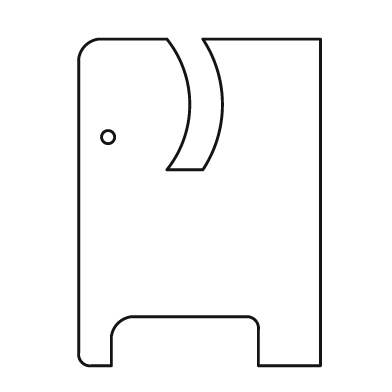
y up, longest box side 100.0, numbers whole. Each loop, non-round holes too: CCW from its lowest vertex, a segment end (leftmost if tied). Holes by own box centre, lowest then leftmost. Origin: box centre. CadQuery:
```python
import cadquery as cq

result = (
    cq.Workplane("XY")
    .moveTo(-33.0, -50.0)
    .lineTo(-27.0, -50.0)
    .lineTo(-27.0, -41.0)
    .threePointArc((-25.0, -37.0), (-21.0, -35.0))
    .lineTo(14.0, -35.0)
    .threePointArc((17.0, -36.0), (18.0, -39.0))
    .lineTo(18.0, -50.0)
    .lineTo(37.0, -50.0)
    .lineTo(37.0, 50.0)
    .lineTo(1.0, 50.0)
    .threePointArc((7.0, 30.0), (1.0, 10.0))
    .lineTo(-10.0, 10.0)
    .threePointArc((-3.0, 30.0), (-10.0, 50.0))
    .lineTo(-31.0, 50.0)
    .threePointArc((-35.0, 48.0), (-37.0, 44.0))
    .lineTo(-37.0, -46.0)
    .threePointArc((-36.0, -49.0), (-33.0, -50.0))
    .close()
    .moveTo(-28.0, 20.0)
    .circle(2.0)
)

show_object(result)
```